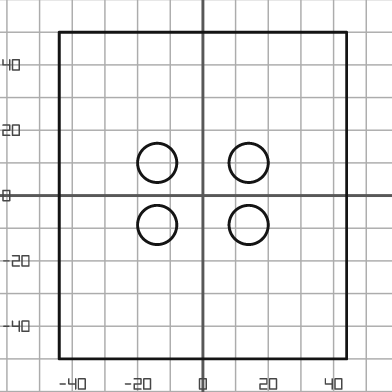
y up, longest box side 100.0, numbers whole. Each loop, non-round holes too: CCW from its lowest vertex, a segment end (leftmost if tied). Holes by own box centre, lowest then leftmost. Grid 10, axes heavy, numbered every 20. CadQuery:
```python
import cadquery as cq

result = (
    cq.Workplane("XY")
    .moveTo(-44.0, -50.0)
    .lineTo(44.0, -50.0)
    .lineTo(44.0, 50.0)
    .lineTo(-44.0, 50.0)
    .close()
    .moveTo(-14.0, -9.0)
    .circle(6.0)
    .moveTo(14.0, -9.0)
    .circle(6.0)
    .moveTo(-14.0, 10.0)
    .circle(6.0)
    .moveTo(14.0, 10.0)
    .circle(6.0)
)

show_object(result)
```